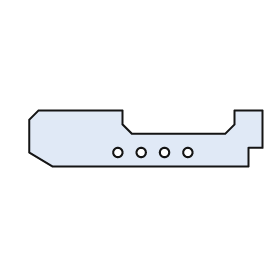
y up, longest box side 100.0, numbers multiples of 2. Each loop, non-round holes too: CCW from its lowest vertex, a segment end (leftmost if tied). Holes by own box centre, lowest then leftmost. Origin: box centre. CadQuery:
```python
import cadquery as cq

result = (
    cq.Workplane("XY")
    .moveTo(-40.0, -12.0)
    .lineTo(44.0, -12.0)
    .lineTo(44.0, -4.0)
    .lineTo(50.0, -4.0)
    .lineTo(50.0, 12.0)
    .lineTo(38.0, 12.0)
    .lineTo(38.0, 6.0)
    .lineTo(34.0, 2.0)
    .lineTo(-6.0, 2.0)
    .lineTo(-10.0, 6.0)
    .lineTo(-10.0, 12.0)
    .lineTo(-46.0, 12.0)
    .lineTo(-50.0, 8.0)
    .lineTo(-50.0, -6.0)
    .close()
    .moveTo(-12.0, -6.0)
    .circle(2.0)
    .moveTo(-2.0, -6.0)
    .circle(2.0)
    .moveTo(8.0, -6.0)
    .circle(2.0)
    .moveTo(18.0, -6.0)
    .circle(2.0)
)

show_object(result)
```